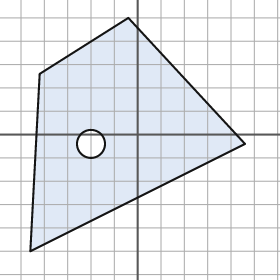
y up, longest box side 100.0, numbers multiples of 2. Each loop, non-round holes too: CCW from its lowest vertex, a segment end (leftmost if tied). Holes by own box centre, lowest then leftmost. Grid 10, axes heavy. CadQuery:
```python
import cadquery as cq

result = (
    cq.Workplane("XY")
    .moveTo(-46.0, -50.0)
    .lineTo(46.0, -4.0)
    .lineTo(-4.0, 50.0)
    .lineTo(-42.0, 26.0)
    .close()
    .moveTo(-20.0, -4.0)
    .circle(6.0)
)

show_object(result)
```